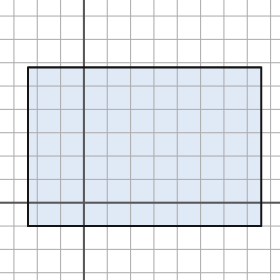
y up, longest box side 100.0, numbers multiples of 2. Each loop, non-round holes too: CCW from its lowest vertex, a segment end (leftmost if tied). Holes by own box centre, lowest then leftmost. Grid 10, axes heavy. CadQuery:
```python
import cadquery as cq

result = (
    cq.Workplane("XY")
    .moveTo(-24.0, -10.0)
    .lineTo(76.0, -10.0)
    .lineTo(76.0, 58.0)
    .lineTo(-24.0, 58.0)
    .close()
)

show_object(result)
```